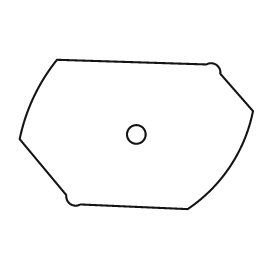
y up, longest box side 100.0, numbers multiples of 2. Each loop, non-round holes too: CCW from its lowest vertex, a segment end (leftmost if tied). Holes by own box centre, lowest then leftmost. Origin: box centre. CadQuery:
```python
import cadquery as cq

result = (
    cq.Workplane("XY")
    .moveTo(22.0, -32.0)
    .threePointArc((40.0, -14.0), (50.0, 10.0))
    .lineTo(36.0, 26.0)
    .threePointArc((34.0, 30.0), (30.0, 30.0))
    .lineTo(-34.0, 32.0)
    .threePointArc((-44.0, 16.0), (-50.0, -2.0))
    .lineTo(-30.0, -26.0)
    .threePointArc((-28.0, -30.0), (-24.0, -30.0))
    .close()
    .moveTo(0.0, 0.0)
    .circle(4.0)
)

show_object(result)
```